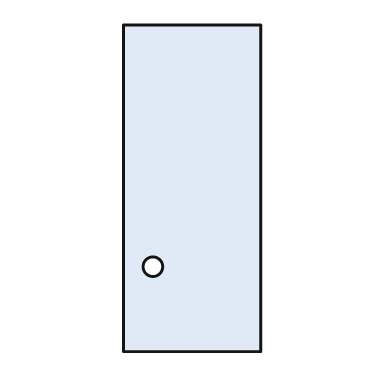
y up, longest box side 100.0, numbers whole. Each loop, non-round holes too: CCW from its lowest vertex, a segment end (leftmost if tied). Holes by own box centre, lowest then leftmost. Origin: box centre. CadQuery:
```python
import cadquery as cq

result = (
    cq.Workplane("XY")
    .moveTo(-21.0, -50.0)
    .lineTo(21.0, -50.0)
    .lineTo(21.0, 50.0)
    .lineTo(-21.0, 50.0)
    .close()
    .moveTo(-12.0, -24.0)
    .circle(3.0)
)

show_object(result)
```